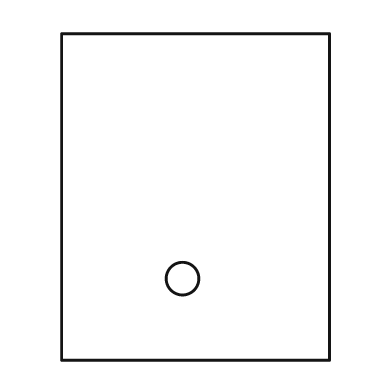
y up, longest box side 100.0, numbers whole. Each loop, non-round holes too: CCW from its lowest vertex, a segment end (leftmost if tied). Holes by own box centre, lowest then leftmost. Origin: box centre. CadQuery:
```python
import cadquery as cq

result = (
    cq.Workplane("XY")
    .moveTo(-41.0, -50.0)
    .lineTo(41.0, -50.0)
    .lineTo(41.0, 50.0)
    .lineTo(-41.0, 50.0)
    .close()
    .moveTo(-4.0, -25.0)
    .circle(5.0)
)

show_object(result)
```